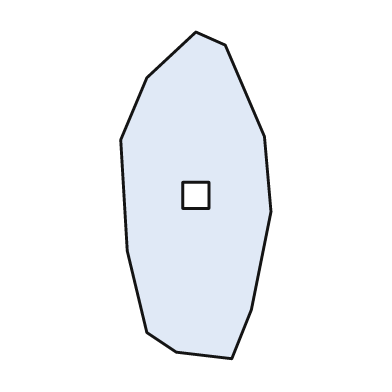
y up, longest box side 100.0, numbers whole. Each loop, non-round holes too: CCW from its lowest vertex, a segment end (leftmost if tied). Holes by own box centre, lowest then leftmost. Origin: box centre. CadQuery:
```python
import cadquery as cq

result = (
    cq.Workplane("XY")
    .moveTo(11.0, -50.0)
    .lineTo(17.0, -35.0)
    .lineTo(23.0, -5.0)
    .lineTo(21.0, 18.0)
    .lineTo(9.0, 46.0)
    .lineTo(0.0, 50.0)
    .lineTo(-15.0, 36.0)
    .lineTo(-23.0, 17.0)
    .lineTo(-21.0, -17.0)
    .lineTo(-15.0, -42.0)
    .lineTo(-6.0, -48.0)
    .close()
    .moveTo(-4.0, -4.0)
    .lineTo(4.0, -4.0)
    .lineTo(4.0, 4.0)
    .lineTo(-4.0, 4.0)
    .close()
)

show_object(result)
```